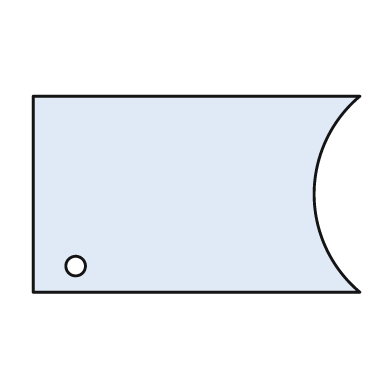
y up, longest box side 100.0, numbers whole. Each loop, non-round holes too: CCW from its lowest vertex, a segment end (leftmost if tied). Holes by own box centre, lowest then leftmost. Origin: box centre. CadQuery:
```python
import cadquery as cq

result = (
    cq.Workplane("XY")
    .moveTo(-50.0, -30.0)
    .lineTo(50.0, -30.0)
    .threePointArc((36.0, 0.0), (50.0, 30.0))
    .lineTo(-50.0, 30.0)
    .close()
    .moveTo(-37.0, -22.0)
    .circle(3.0)
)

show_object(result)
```